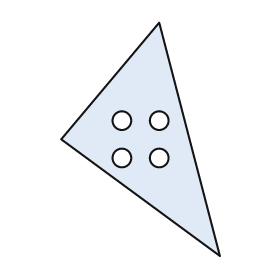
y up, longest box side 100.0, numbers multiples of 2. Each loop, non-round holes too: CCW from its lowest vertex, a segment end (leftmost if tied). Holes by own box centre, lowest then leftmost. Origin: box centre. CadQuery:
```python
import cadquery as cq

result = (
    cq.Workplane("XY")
    .moveTo(34.0, -50.0)
    .lineTo(8.0, 50.0)
    .lineTo(-34.0, 0.0)
    .close()
    .moveTo(-8.0, -8.0)
    .circle(4.0)
    .moveTo(8.0, -8.0)
    .circle(4.0)
    .moveTo(-8.0, 8.0)
    .circle(4.0)
    .moveTo(8.0, 8.0)
    .circle(4.0)
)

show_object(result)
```